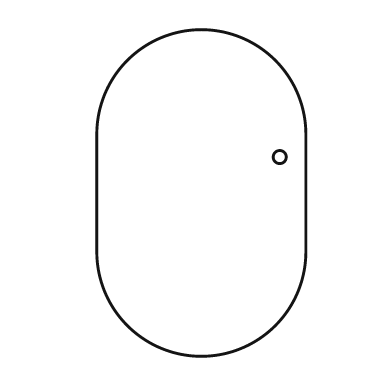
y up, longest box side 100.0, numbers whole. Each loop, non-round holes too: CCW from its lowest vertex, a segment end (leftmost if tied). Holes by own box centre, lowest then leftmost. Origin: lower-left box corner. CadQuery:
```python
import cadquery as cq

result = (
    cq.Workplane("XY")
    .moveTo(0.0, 32.0)
    .threePointArc((32.0, 0.0), (64.0, 32.0))
    .lineTo(64.0, 68.0)
    .threePointArc((32.0, 100.0), (0.0, 68.0))
    .close()
    .moveTo(56.0, 61.0)
    .circle(2.0)
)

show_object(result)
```